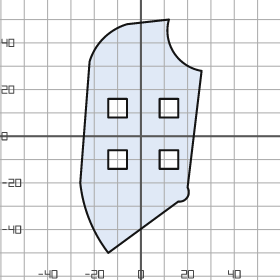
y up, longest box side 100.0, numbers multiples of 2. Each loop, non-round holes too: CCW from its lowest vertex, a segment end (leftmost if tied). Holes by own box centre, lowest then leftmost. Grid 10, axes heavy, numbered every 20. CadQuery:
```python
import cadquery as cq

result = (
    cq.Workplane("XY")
    .moveTo(-14.0, -50.0)
    .lineTo(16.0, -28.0)
    .threePointArc((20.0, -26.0), (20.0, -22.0))
    .lineTo(26.0, 28.0)
    .threePointArc((14.0, 36.0), (12.0, 50.0))
    .lineTo(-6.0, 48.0)
    .threePointArc((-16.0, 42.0), (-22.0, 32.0))
    .lineTo(-26.0, -20.0)
    .threePointArc((-22.0, -36.0), (-14.0, -50.0))
    .close()
    .moveTo(-14.0, -14.0)
    .lineTo(-6.0, -14.0)
    .lineTo(-6.0, -6.0)
    .lineTo(-14.0, -6.0)
    .close()
    .moveTo(8.0, -14.0)
    .lineTo(16.0, -14.0)
    .lineTo(16.0, -6.0)
    .lineTo(8.0, -6.0)
    .close()
    .moveTo(-14.0, 8.0)
    .lineTo(-6.0, 8.0)
    .lineTo(-6.0, 16.0)
    .lineTo(-14.0, 16.0)
    .close()
    .moveTo(8.0, 8.0)
    .lineTo(16.0, 8.0)
    .lineTo(16.0, 16.0)
    .lineTo(8.0, 16.0)
    .close()
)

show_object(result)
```